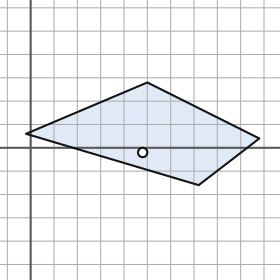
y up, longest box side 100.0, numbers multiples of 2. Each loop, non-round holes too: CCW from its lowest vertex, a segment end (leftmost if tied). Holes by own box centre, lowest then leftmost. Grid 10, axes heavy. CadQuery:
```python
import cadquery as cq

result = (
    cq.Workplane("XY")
    .moveTo(72.0, -16.0)
    .lineTo(98.0, 4.0)
    .lineTo(50.0, 28.0)
    .lineTo(-2.0, 6.0)
    .close()
    .moveTo(48.0, -2.0)
    .circle(2.0)
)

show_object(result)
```